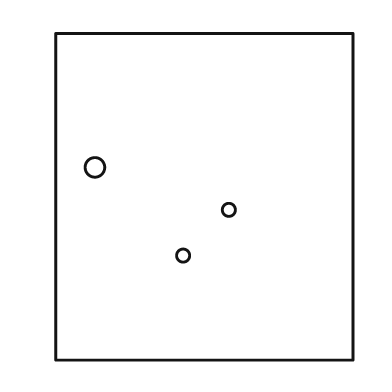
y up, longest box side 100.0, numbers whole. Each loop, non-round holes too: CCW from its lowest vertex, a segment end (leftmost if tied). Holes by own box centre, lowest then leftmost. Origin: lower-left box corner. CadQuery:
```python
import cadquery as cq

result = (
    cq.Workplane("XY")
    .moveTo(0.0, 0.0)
    .lineTo(91.0, 0.0)
    .lineTo(91.0, 100.0)
    .lineTo(0.0, 100.0)
    .close()
    .moveTo(39.0, 32.0)
    .circle(2.0)
    .moveTo(53.0, 46.0)
    .circle(2.0)
    .moveTo(12.0, 59.0)
    .circle(3.0)
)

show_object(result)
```